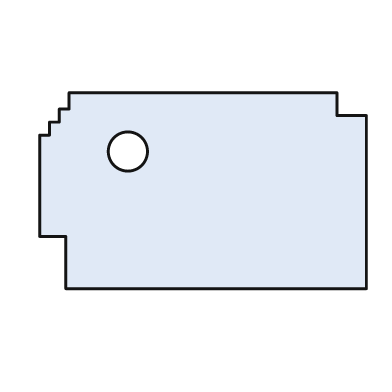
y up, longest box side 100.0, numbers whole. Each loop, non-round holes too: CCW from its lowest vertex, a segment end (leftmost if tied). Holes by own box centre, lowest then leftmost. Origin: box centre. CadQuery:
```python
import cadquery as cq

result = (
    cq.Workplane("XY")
    .moveTo(-42.0, -30.0)
    .lineTo(50.0, -30.0)
    .lineTo(50.0, 23.0)
    .lineTo(41.0, 23.0)
    .lineTo(41.0, 30.0)
    .lineTo(-41.0, 30.0)
    .lineTo(-41.0, 25.0)
    .lineTo(-44.0, 25.0)
    .lineTo(-44.0, 21.0)
    .lineTo(-47.0, 21.0)
    .lineTo(-47.0, 17.0)
    .lineTo(-50.0, 17.0)
    .lineTo(-50.0, -14.0)
    .lineTo(-42.0, -14.0)
    .close()
    .moveTo(-23.0, 12.0)
    .circle(6.0)
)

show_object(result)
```